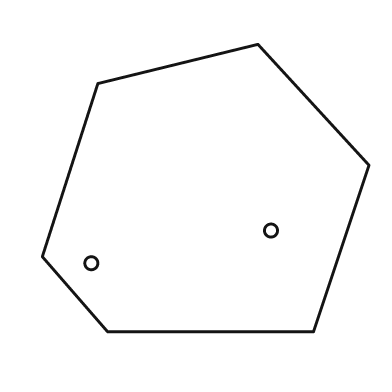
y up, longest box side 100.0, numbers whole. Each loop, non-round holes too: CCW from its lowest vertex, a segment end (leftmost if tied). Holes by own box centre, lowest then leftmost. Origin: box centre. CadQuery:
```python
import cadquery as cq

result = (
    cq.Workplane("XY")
    .moveTo(-30.0, -44.0)
    .lineTo(33.0, -44.0)
    .lineTo(50.0, 7.0)
    .lineTo(16.0, 44.0)
    .lineTo(-33.0, 32.0)
    .lineTo(-50.0, -21.0)
    .close()
    .moveTo(-35.0, -23.0)
    .circle(2.0)
    .moveTo(20.0, -13.0)
    .circle(2.0)
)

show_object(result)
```